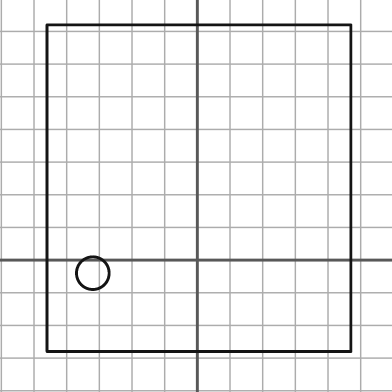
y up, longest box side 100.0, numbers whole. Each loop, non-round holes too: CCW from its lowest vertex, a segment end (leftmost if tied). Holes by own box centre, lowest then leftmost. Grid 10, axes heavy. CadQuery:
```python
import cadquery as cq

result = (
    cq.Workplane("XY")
    .moveTo(-46.0, -28.0)
    .lineTo(47.0, -28.0)
    .lineTo(47.0, 72.0)
    .lineTo(-46.0, 72.0)
    .close()
    .moveTo(-32.0, -4.0)
    .circle(5.0)
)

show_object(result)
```